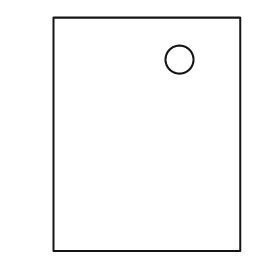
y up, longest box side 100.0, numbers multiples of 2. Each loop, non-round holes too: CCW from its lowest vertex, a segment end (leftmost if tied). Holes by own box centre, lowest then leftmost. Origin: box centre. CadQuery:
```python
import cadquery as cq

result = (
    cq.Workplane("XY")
    .moveTo(-40.0, -50.0)
    .lineTo(40.0, -50.0)
    .lineTo(40.0, 50.0)
    .lineTo(-40.0, 50.0)
    .close()
    .moveTo(14.0, 32.0)
    .circle(6.0)
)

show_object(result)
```